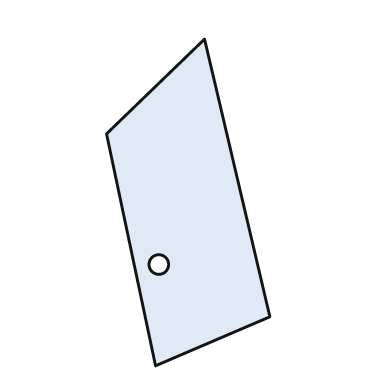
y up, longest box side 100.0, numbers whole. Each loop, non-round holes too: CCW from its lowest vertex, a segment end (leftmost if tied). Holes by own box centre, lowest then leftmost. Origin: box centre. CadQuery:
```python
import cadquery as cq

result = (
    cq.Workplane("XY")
    .moveTo(-10.0, -50.0)
    .lineTo(25.0, -35.0)
    .lineTo(5.0, 50.0)
    .lineTo(-25.0, 21.0)
    .close()
    .moveTo(-9.0, -19.0)
    .circle(3.0)
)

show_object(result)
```